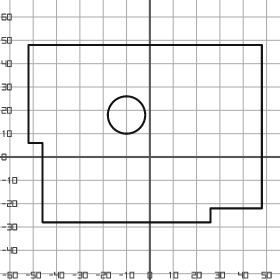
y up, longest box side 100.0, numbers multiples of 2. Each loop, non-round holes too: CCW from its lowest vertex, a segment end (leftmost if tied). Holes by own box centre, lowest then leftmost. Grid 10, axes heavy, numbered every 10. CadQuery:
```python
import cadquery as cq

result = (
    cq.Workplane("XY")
    .moveTo(-46.0, -28.0)
    .lineTo(26.0, -28.0)
    .lineTo(26.0, -22.0)
    .lineTo(48.0, -22.0)
    .lineTo(48.0, 48.0)
    .lineTo(-52.0, 48.0)
    .lineTo(-52.0, 6.0)
    .lineTo(-46.0, 6.0)
    .close()
    .moveTo(-10.0, 18.0)
    .circle(8.0)
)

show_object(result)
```